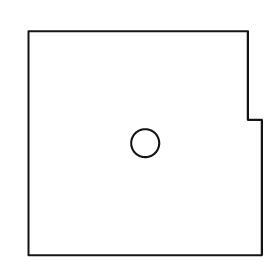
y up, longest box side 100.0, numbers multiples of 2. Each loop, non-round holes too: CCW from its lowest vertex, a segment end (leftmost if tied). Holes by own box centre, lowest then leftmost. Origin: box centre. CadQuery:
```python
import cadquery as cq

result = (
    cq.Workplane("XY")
    .moveTo(-50.0, -48.0)
    .lineTo(50.0, -48.0)
    .lineTo(50.0, 10.0)
    .lineTo(44.0, 10.0)
    .lineTo(44.0, 48.0)
    .lineTo(-50.0, 48.0)
    .close()
    .moveTo(0.0, 0.0)
    .circle(6.0)
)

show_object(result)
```